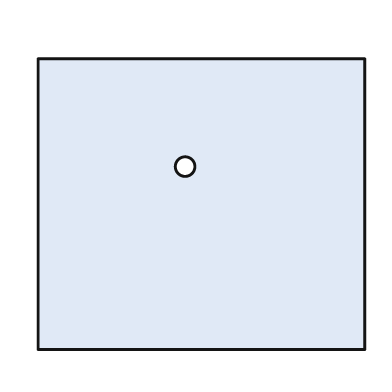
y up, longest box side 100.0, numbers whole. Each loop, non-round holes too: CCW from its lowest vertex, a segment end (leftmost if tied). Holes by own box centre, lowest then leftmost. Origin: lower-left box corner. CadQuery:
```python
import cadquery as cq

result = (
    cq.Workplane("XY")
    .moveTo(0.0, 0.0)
    .lineTo(100.0, 0.0)
    .lineTo(100.0, 89.0)
    .lineTo(0.0, 89.0)
    .close()
    .moveTo(45.0, 56.0)
    .circle(3.0)
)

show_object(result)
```